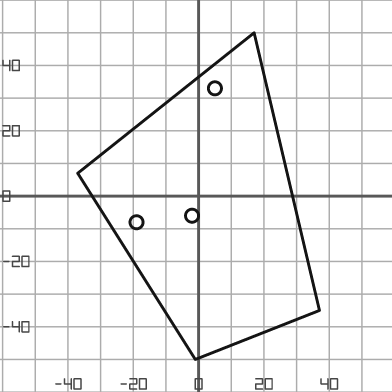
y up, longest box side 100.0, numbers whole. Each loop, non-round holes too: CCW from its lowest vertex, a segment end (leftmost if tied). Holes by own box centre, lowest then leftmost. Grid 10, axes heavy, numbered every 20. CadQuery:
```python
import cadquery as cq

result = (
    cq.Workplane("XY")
    .moveTo(-1.0, -50.0)
    .lineTo(37.0, -35.0)
    .lineTo(17.0, 50.0)
    .lineTo(-37.0, 7.0)
    .close()
    .moveTo(-19.0, -8.0)
    .circle(2.0)
    .moveTo(-2.0, -6.0)
    .circle(2.0)
    .moveTo(5.0, 33.0)
    .circle(2.0)
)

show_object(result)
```